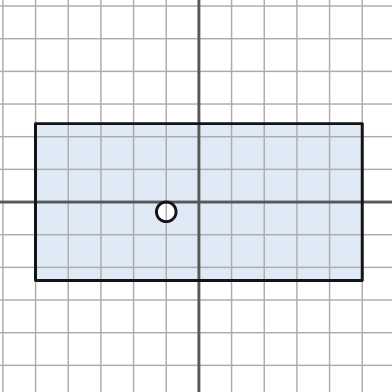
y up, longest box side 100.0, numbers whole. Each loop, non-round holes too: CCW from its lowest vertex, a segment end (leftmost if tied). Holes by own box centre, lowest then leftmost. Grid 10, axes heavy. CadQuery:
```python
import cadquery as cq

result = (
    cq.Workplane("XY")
    .moveTo(-50.0, -24.0)
    .lineTo(50.0, -24.0)
    .lineTo(50.0, 24.0)
    .lineTo(-50.0, 24.0)
    .close()
    .moveTo(-10.0, -3.0)
    .circle(3.0)
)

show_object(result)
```